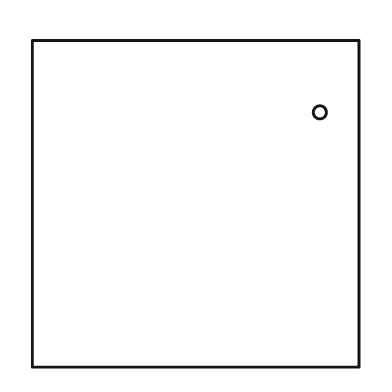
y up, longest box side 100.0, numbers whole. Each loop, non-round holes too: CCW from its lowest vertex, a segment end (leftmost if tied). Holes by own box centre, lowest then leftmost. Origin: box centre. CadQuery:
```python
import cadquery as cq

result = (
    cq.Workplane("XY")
    .moveTo(-50.0, -50.0)
    .lineTo(50.0, -50.0)
    .lineTo(50.0, 50.0)
    .lineTo(-50.0, 50.0)
    .close()
    .moveTo(38.0, 28.0)
    .circle(2.0)
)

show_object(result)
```